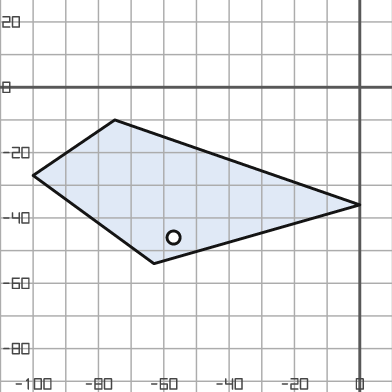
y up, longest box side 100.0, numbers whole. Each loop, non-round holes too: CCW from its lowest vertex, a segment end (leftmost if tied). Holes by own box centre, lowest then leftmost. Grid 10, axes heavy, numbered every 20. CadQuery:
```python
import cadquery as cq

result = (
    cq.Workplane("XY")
    .moveTo(-63.0, -54.0)
    .lineTo(0.0, -36.0)
    .lineTo(-75.0, -10.0)
    .lineTo(-100.0, -27.0)
    .close()
    .moveTo(-57.0, -46.0)
    .circle(2.0)
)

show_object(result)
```